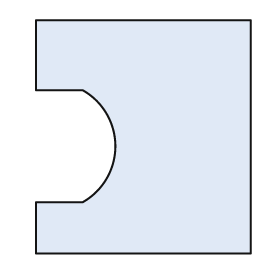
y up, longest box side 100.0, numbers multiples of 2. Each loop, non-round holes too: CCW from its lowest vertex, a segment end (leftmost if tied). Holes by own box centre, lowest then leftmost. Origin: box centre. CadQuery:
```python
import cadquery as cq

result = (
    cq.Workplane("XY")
    .moveTo(-46.0, -50.0)
    .lineTo(46.0, -50.0)
    .lineTo(46.0, 50.0)
    .lineTo(-46.0, 50.0)
    .lineTo(-46.0, 20.0)
    .lineTo(-26.0, 20.0)
    .threePointArc((-12.0, -4.0), (-26.0, -28.0))
    .lineTo(-46.0, -28.0)
    .close()
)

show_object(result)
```